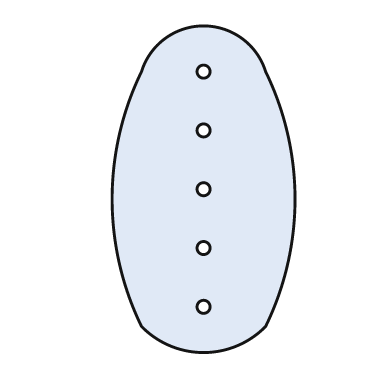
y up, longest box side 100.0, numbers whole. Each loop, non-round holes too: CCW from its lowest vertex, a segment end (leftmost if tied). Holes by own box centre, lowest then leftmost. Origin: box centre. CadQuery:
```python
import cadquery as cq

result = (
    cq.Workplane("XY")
    .moveTo(-19.0, -42.0)
    .threePointArc((0.0, -50.0), (19.0, -42.0))
    .threePointArc((28.0, -3.0), (19.0, 36.0))
    .threePointArc((0.0, 50.0), (-19.0, 36.0))
    .threePointArc((-28.0, -3.0), (-19.0, -42.0))
    .close()
    .moveTo(0.0, -36.0)
    .circle(2.0)
    .moveTo(0.0, -18.0)
    .circle(2.0)
    .moveTo(0.0, 0.0)
    .circle(2.0)
    .moveTo(0.0, 18.0)
    .circle(2.0)
    .moveTo(0.0, 36.0)
    .circle(2.0)
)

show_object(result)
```